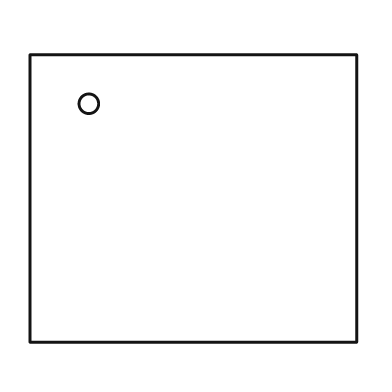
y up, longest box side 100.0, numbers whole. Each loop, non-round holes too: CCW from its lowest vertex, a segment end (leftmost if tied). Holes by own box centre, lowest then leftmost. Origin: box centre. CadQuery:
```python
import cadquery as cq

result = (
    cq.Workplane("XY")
    .moveTo(-50.0, -44.0)
    .lineTo(50.0, -44.0)
    .lineTo(50.0, 44.0)
    .lineTo(-50.0, 44.0)
    .close()
    .moveTo(-32.0, 29.0)
    .circle(3.0)
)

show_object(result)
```